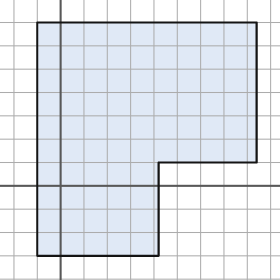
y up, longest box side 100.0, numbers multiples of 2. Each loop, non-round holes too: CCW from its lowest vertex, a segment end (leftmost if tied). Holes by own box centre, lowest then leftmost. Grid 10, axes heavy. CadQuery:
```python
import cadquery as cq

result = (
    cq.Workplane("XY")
    .moveTo(-10.0, -30.0)
    .lineTo(42.0, -30.0)
    .lineTo(42.0, 10.0)
    .lineTo(84.0, 10.0)
    .lineTo(84.0, 70.0)
    .lineTo(-10.0, 70.0)
    .close()
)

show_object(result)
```